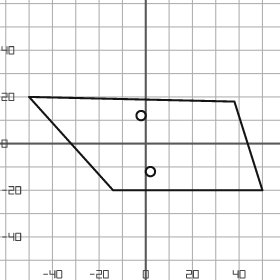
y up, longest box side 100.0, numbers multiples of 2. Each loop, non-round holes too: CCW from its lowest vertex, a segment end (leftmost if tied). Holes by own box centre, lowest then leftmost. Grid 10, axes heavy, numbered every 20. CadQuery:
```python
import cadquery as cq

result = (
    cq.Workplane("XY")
    .moveTo(-14.0, -20.0)
    .lineTo(50.0, -20.0)
    .lineTo(38.0, 18.0)
    .lineTo(-50.0, 20.0)
    .close()
    .moveTo(2.0, -12.0)
    .circle(2.0)
    .moveTo(-2.0, 12.0)
    .circle(2.0)
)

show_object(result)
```